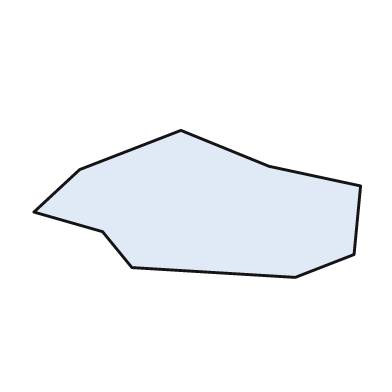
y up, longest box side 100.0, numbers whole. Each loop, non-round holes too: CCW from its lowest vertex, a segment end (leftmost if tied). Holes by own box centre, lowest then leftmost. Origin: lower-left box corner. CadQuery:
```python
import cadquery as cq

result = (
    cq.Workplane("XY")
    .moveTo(80.0, 0.0)
    .lineTo(98.0, 7.0)
    .lineTo(100.0, 28.0)
    .lineTo(72.0, 34.0)
    .lineTo(45.0, 45.0)
    .lineTo(14.0, 33.0)
    .lineTo(0.0, 20.0)
    .lineTo(21.0, 14.0)
    .lineTo(30.0, 3.0)
    .close()
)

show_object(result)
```